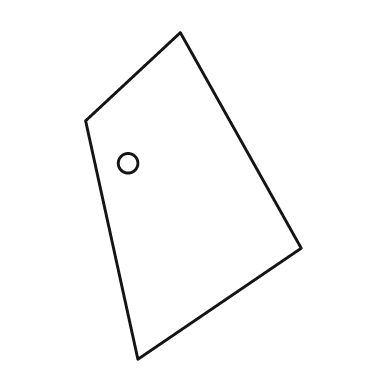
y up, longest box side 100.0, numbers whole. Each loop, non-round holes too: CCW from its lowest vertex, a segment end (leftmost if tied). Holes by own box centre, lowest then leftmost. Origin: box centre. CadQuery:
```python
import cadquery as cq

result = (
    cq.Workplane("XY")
    .moveTo(-17.0, -50.0)
    .lineTo(33.0, -16.0)
    .lineTo(-4.0, 50.0)
    .lineTo(-33.0, 23.0)
    .close()
    .moveTo(-20.0, 10.0)
    .circle(3.0)
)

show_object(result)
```